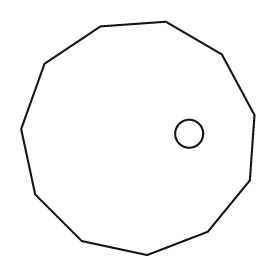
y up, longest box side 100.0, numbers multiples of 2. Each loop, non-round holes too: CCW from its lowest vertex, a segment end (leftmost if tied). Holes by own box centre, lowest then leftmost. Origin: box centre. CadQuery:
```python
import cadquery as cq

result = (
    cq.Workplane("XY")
    .moveTo(4.0, -50.0)
    .lineTo(30.0, -40.0)
    .lineTo(48.0, -18.0)
    .lineTo(50.0, 10.0)
    .lineTo(36.0, 36.0)
    .lineTo(12.0, 50.0)
    .lineTo(-16.0, 48.0)
    .lineTo(-40.0, 32.0)
    .lineTo(-50.0, 4.0)
    .lineTo(-44.0, -24.0)
    .lineTo(-24.0, -44.0)
    .close()
    .moveTo(22.0, 2.0)
    .circle(6.0)
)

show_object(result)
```